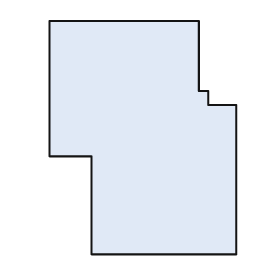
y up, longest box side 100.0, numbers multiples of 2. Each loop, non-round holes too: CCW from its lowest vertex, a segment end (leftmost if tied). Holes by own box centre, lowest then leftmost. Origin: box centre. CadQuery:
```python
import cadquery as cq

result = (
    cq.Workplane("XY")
    .moveTo(-22.0, -50.0)
    .lineTo(40.0, -50.0)
    .lineTo(40.0, 14.0)
    .lineTo(28.0, 14.0)
    .lineTo(28.0, 20.0)
    .lineTo(24.0, 20.0)
    .lineTo(24.0, 50.0)
    .lineTo(-40.0, 50.0)
    .lineTo(-40.0, -8.0)
    .lineTo(-22.0, -8.0)
    .close()
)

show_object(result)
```